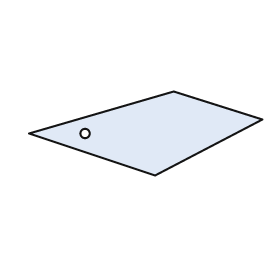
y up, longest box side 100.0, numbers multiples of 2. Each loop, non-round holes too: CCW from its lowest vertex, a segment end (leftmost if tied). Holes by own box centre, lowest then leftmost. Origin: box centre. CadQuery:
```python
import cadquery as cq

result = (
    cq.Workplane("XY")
    .moveTo(4.0, -18.0)
    .lineTo(50.0, 6.0)
    .lineTo(12.0, 18.0)
    .lineTo(-50.0, 0.0)
    .close()
    .moveTo(-26.0, 0.0)
    .circle(2.0)
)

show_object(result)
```